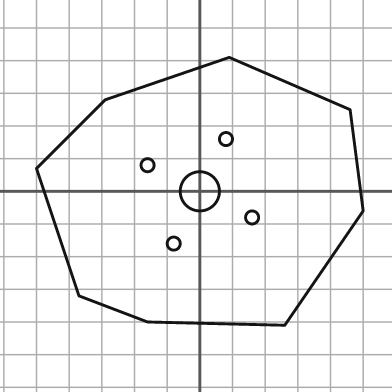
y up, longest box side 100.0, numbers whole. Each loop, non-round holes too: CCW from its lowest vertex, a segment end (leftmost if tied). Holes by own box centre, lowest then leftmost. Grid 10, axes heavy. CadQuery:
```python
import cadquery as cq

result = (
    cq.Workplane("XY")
    .moveTo(26.0, -41.0)
    .lineTo(50.0, -6.0)
    .lineTo(46.0, 25.0)
    .lineTo(9.0, 41.0)
    .lineTo(-29.0, 28.0)
    .lineTo(-50.0, 7.0)
    .lineTo(-37.0, -32.0)
    .lineTo(-16.0, -40.0)
    .close()
    .moveTo(-8.0, -16.0)
    .circle(2.0)
    .moveTo(16.0, -8.0)
    .circle(2.0)
    .moveTo(0.0, 0.0)
    .circle(6.0)
    .moveTo(-16.0, 8.0)
    .circle(2.0)
    .moveTo(8.0, 16.0)
    .circle(2.0)
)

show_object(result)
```